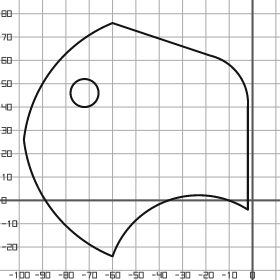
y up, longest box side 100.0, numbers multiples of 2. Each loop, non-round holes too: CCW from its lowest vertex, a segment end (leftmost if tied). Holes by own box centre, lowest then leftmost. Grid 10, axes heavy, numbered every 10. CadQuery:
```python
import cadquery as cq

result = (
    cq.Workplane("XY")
    .moveTo(-60.0, -24.0)
    .threePointArc((-36.0, 0.0), (-2.0, -4.0))
    .lineTo(-2.0, 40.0)
    .threePointArc((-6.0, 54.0), (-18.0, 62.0))
    .lineTo(-60.0, 76.0)
    .threePointArc((-86.0, 56.0), (-98.0, 26.0))
    .threePointArc((-86.0, -4.0), (-60.0, -24.0))
    .close()
    .moveTo(-72.0, 46.0)
    .circle(6.0)
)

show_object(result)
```